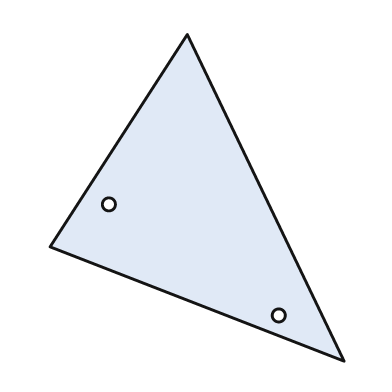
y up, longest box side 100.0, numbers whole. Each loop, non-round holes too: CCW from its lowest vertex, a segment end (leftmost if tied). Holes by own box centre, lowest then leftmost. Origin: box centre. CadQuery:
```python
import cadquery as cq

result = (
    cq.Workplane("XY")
    .moveTo(45.0, -50.0)
    .lineTo(-3.0, 50.0)
    .lineTo(-45.0, -15.0)
    .close()
    .moveTo(25.0, -36.0)
    .circle(2.0)
    .moveTo(-27.0, -2.0)
    .circle(2.0)
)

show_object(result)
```